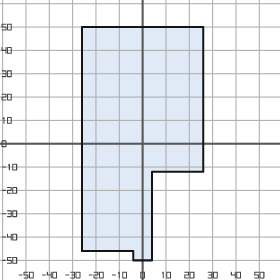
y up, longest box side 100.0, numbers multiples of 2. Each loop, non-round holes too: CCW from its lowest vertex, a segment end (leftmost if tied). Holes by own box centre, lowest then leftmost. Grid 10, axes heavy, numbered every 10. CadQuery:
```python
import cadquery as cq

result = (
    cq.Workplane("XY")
    .moveTo(-4.0, -50.0)
    .lineTo(4.0, -50.0)
    .lineTo(4.0, -12.0)
    .lineTo(26.0, -12.0)
    .lineTo(26.0, 50.0)
    .lineTo(-26.0, 50.0)
    .lineTo(-26.0, -46.0)
    .lineTo(-4.0, -46.0)
    .close()
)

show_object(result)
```